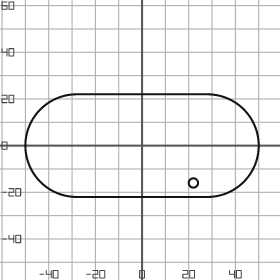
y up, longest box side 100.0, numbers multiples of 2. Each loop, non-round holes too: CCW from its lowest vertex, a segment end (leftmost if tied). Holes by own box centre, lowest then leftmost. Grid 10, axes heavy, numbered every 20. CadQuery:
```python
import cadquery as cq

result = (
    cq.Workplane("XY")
    .moveTo(-28.0, -22.0)
    .lineTo(28.0, -22.0)
    .threePointArc((50.0, 0.0), (28.0, 22.0))
    .lineTo(-28.0, 22.0)
    .threePointArc((-50.0, 0.0), (-28.0, -22.0))
    .close()
    .moveTo(22.0, -16.0)
    .circle(2.0)
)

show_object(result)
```